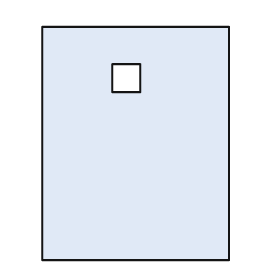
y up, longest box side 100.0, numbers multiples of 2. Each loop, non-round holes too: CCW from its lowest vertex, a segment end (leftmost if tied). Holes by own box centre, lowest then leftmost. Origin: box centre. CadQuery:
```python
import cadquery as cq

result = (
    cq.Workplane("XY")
    .moveTo(-40.0, -50.0)
    .lineTo(40.0, -50.0)
    .lineTo(40.0, 50.0)
    .lineTo(-40.0, 50.0)
    .close()
    .moveTo(-10.0, 22.0)
    .lineTo(2.0, 22.0)
    .lineTo(2.0, 34.0)
    .lineTo(-10.0, 34.0)
    .close()
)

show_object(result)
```